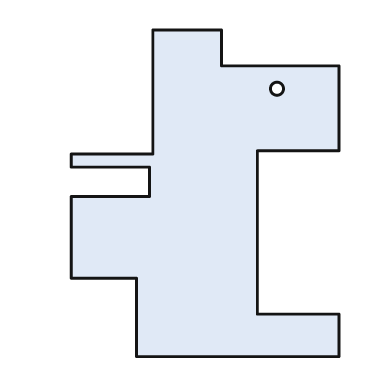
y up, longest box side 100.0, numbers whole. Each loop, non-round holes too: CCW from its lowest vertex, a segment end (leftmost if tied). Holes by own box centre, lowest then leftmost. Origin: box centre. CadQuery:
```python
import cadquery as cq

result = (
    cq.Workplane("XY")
    .moveTo(-21.0, -50.0)
    .lineTo(41.0, -50.0)
    .lineTo(41.0, -37.0)
    .lineTo(16.0, -37.0)
    .lineTo(16.0, 13.0)
    .lineTo(41.0, 13.0)
    .lineTo(41.0, 39.0)
    .lineTo(5.0, 39.0)
    .lineTo(5.0, 50.0)
    .lineTo(-16.0, 50.0)
    .lineTo(-16.0, 12.0)
    .lineTo(-41.0, 12.0)
    .lineTo(-41.0, 8.0)
    .lineTo(-17.0, 8.0)
    .lineTo(-17.0, -1.0)
    .lineTo(-41.0, -1.0)
    .lineTo(-41.0, -26.0)
    .lineTo(-21.0, -26.0)
    .close()
    .moveTo(22.0, 32.0)
    .circle(2.0)
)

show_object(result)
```